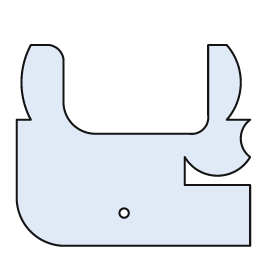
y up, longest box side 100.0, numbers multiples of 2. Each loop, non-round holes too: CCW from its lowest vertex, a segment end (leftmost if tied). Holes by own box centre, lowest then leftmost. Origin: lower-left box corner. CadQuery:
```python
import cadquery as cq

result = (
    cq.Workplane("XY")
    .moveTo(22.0, 0.0)
    .lineTo(100.0, 0.0)
    .lineTo(100.0, 26.0)
    .lineTo(72.0, 26.0)
    .lineTo(72.0, 38.0)
    .threePointArc((86.0, 30.0), (100.0, 38.0))
    .threePointArc((96.0, 46.0), (100.0, 54.0))
    .lineTo(90.0, 54.0)
    .threePointArc((96.0, 70.0), (90.0, 86.0))
    .lineTo(82.0, 86.0)
    .lineTo(82.0, 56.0)
    .threePointArc((80.0, 50.0), (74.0, 48.0))
    .lineTo(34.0, 48.0)
    .threePointArc((24.0, 52.0), (20.0, 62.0))
    .lineTo(20.0, 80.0)
    .threePointArc((18.0, 84.0), (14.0, 86.0))
    .lineTo(6.0, 86.0)
    .threePointArc((2.0, 70.0), (6.0, 54.0))
    .lineTo(0.0, 54.0)
    .lineTo(0.0, 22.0)
    .threePointArc((6.0, 6.0), (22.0, 0.0))
    .close()
    .moveTo(46.0, 14.0)
    .circle(2.0)
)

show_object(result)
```